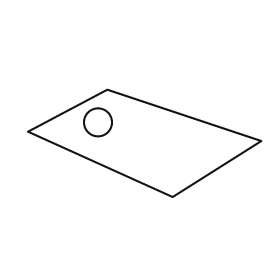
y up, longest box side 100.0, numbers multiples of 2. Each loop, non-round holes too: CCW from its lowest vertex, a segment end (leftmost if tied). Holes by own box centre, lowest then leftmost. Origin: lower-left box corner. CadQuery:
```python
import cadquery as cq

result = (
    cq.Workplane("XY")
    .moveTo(62.0, 0.0)
    .lineTo(100.0, 24.0)
    .lineTo(34.0, 46.0)
    .lineTo(0.0, 28.0)
    .close()
    .moveTo(30.0, 32.0)
    .circle(6.0)
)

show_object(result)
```